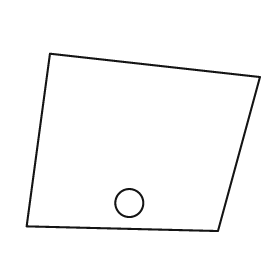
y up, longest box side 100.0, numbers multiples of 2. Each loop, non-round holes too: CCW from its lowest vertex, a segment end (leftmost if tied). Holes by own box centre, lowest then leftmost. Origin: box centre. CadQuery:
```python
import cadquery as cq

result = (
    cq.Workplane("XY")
    .moveTo(32.0, -38.0)
    .lineTo(50.0, 28.0)
    .lineTo(-40.0, 38.0)
    .lineTo(-50.0, -36.0)
    .close()
    .moveTo(-6.0, -26.0)
    .circle(6.0)
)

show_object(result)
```